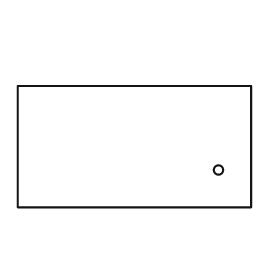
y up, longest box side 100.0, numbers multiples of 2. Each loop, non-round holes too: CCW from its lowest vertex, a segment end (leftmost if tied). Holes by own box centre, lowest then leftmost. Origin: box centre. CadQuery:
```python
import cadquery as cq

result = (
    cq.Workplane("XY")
    .moveTo(-50.0, -26.0)
    .lineTo(50.0, -26.0)
    .lineTo(50.0, 26.0)
    .lineTo(-50.0, 26.0)
    .close()
    .moveTo(36.0, -10.0)
    .circle(2.0)
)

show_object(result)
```